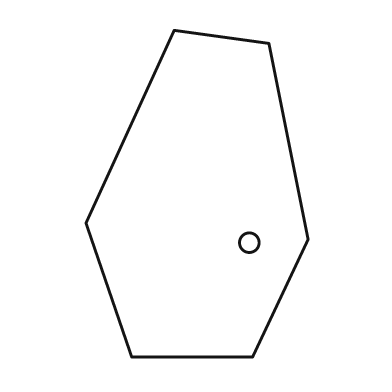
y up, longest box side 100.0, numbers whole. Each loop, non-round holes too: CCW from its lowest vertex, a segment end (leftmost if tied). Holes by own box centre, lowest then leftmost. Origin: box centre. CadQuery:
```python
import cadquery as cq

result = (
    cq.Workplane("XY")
    .moveTo(-20.0, -50.0)
    .lineTo(17.0, -50.0)
    .lineTo(34.0, -14.0)
    .lineTo(22.0, 46.0)
    .lineTo(-7.0, 50.0)
    .lineTo(-34.0, -9.0)
    .close()
    .moveTo(16.0, -15.0)
    .circle(3.0)
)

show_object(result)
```